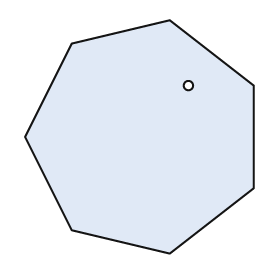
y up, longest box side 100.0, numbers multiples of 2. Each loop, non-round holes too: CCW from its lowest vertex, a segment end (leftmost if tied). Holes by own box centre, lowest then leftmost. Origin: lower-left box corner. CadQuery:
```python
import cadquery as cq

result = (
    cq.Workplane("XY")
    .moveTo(62.0, 0.0)
    .lineTo(98.0, 28.0)
    .lineTo(98.0, 72.0)
    .lineTo(62.0, 100.0)
    .lineTo(20.0, 90.0)
    .lineTo(0.0, 50.0)
    .lineTo(20.0, 10.0)
    .close()
    .moveTo(70.0, 72.0)
    .circle(2.0)
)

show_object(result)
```